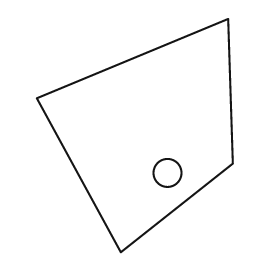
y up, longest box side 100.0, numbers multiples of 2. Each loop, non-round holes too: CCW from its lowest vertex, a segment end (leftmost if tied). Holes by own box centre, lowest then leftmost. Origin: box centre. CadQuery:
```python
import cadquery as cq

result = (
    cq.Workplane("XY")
    .moveTo(-6.0, -50.0)
    .lineTo(42.0, -12.0)
    .lineTo(40.0, 50.0)
    .lineTo(-42.0, 16.0)
    .close()
    .moveTo(14.0, -16.0)
    .circle(6.0)
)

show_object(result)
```